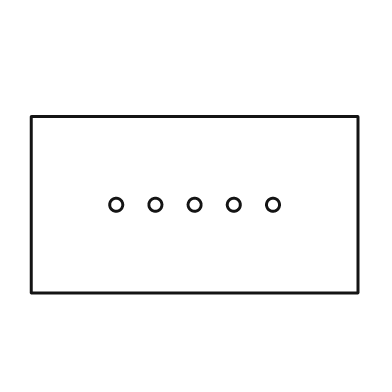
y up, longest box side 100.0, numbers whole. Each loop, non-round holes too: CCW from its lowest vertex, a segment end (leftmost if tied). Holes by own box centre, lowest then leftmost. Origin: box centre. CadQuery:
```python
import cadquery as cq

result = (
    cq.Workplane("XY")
    .moveTo(-50.0, -27.0)
    .lineTo(50.0, -27.0)
    .lineTo(50.0, 27.0)
    .lineTo(-50.0, 27.0)
    .close()
    .moveTo(-24.0, 0.0)
    .circle(2.0)
    .moveTo(-12.0, 0.0)
    .circle(2.0)
    .moveTo(0.0, 0.0)
    .circle(2.0)
    .moveTo(12.0, 0.0)
    .circle(2.0)
    .moveTo(24.0, 0.0)
    .circle(2.0)
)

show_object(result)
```